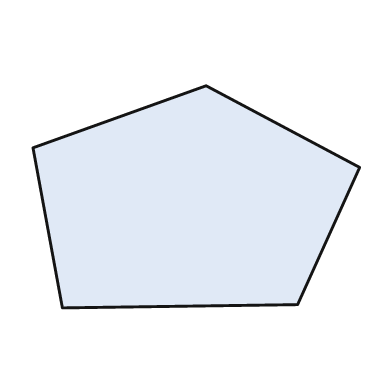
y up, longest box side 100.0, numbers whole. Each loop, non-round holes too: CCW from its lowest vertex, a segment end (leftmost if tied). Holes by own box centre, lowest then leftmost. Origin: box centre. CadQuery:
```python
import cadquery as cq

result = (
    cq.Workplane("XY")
    .moveTo(-41.0, -34.0)
    .lineTo(31.0, -33.0)
    .lineTo(50.0, 9.0)
    .lineTo(3.0, 34.0)
    .lineTo(-50.0, 15.0)
    .close()
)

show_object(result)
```